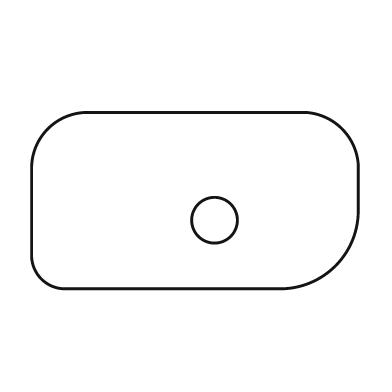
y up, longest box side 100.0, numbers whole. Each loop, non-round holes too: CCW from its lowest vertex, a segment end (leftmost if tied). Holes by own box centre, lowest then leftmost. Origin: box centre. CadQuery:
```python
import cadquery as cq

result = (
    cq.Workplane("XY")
    .moveTo(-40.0, -27.0)
    .lineTo(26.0, -27.0)
    .threePointArc((43.0, -20.0), (50.0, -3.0))
    .lineTo(50.0, 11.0)
    .threePointArc((45.0, 22.0), (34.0, 27.0))
    .lineTo(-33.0, 27.0)
    .threePointArc((-45.0, 22.0), (-50.0, 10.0))
    .lineTo(-50.0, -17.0)
    .threePointArc((-47.0, -24.0), (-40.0, -27.0))
    .close()
    .moveTo(6.0, -6.0)
    .circle(7.0)
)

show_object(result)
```